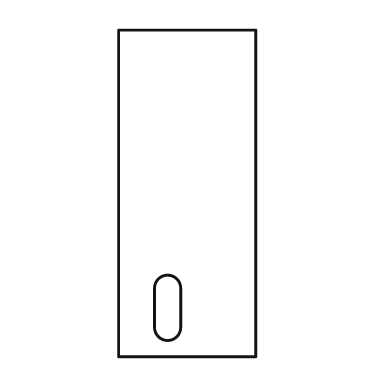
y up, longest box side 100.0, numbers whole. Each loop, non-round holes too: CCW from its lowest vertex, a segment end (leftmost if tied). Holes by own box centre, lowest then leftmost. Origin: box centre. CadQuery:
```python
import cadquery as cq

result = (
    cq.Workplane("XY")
    .moveTo(-21.0, -50.0)
    .lineTo(21.0, -50.0)
    .lineTo(21.0, 50.0)
    .lineTo(-21.0, 50.0)
    .close()
    .moveTo(-10.0, -41.0)
    .threePointArc((-6.0, -45.0), (-2.0, -41.0))
    .lineTo(-2.0, -29.0)
    .threePointArc((-6.0, -25.0), (-10.0, -29.0))
    .close()
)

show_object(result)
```